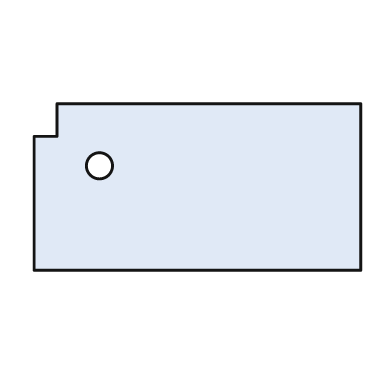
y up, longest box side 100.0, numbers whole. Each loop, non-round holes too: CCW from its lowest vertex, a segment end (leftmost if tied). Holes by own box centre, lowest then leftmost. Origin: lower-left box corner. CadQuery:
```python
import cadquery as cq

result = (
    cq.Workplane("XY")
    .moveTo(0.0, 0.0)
    .lineTo(100.0, 0.0)
    .lineTo(100.0, 51.0)
    .lineTo(7.0, 51.0)
    .lineTo(7.0, 41.0)
    .lineTo(0.0, 41.0)
    .close()
    .moveTo(20.0, 32.0)
    .circle(4.0)
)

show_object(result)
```